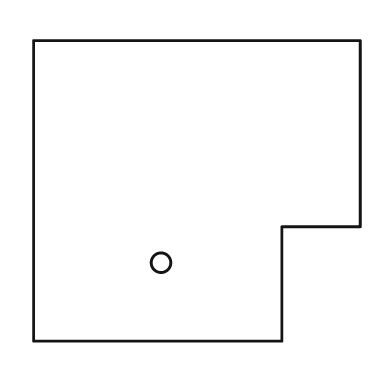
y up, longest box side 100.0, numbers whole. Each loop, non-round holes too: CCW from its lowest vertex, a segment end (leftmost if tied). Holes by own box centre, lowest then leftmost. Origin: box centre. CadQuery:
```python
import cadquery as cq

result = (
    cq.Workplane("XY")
    .moveTo(-50.0, -46.0)
    .lineTo(26.0, -46.0)
    .lineTo(26.0, -11.0)
    .lineTo(50.0, -11.0)
    .lineTo(50.0, 46.0)
    .lineTo(-50.0, 46.0)
    .close()
    .moveTo(-11.0, -22.0)
    .circle(3.0)
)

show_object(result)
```